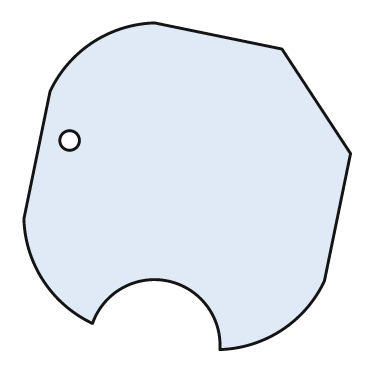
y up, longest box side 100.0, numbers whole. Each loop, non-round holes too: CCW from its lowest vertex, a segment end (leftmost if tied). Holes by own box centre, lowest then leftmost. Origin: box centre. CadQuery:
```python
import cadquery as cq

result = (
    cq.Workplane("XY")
    .moveTo(10.0, -50.0)
    .threePointArc((29.0, -44.0), (42.0, -29.0))
    .lineTo(50.0, 10.0)
    .lineTo(29.0, 42.0)
    .lineTo(-10.0, 50.0)
    .threePointArc((-29.0, 44.0), (-42.0, 29.0))
    .lineTo(-50.0, -10.0)
    .threePointArc((-44.0, -29.0), (-29.0, -42.0))
    .threePointArc((-6.0, -29.0), (10.0, -50.0))
    .close()
    .moveTo(-36.0, 14.0)
    .circle(3.0)
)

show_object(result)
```